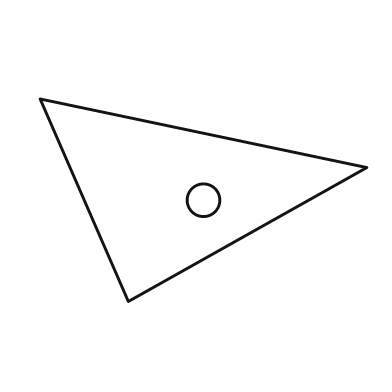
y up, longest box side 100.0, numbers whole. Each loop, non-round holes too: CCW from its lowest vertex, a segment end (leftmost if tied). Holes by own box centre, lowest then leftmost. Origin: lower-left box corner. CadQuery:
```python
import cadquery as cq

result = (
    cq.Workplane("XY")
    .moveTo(27.0, 0.0)
    .lineTo(100.0, 41.0)
    .lineTo(0.0, 62.0)
    .close()
    .moveTo(50.0, 31.0)
    .circle(5.0)
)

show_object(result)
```